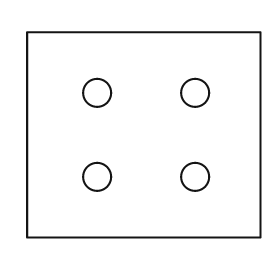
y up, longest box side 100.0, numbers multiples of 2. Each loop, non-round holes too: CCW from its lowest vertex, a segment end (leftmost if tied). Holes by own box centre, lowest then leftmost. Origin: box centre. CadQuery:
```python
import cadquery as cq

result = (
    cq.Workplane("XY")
    .moveTo(-50.0, -44.0)
    .lineTo(50.0, -44.0)
    .lineTo(50.0, 44.0)
    .lineTo(-50.0, 44.0)
    .close()
    .moveTo(-20.0, -18.0)
    .circle(6.0)
    .moveTo(22.0, -18.0)
    .circle(6.0)
    .moveTo(-20.0, 18.0)
    .circle(6.0)
    .moveTo(22.0, 18.0)
    .circle(6.0)
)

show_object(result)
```